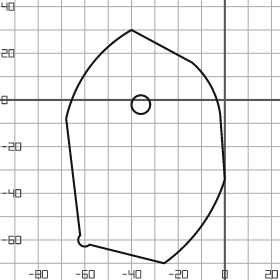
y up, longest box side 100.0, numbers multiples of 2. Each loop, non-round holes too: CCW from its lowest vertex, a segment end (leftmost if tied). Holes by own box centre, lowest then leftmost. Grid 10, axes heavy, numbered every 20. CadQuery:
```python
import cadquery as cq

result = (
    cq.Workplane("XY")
    .moveTo(-26.0, -70.0)
    .threePointArc((-10.0, -54.0), (0.0, -34.0))
    .lineTo(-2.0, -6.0)
    .threePointArc((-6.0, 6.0), (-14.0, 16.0))
    .lineTo(-40.0, 30.0)
    .threePointArc((-58.0, 14.0), (-68.0, -8.0))
    .lineTo(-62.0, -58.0)
    .threePointArc((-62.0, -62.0), (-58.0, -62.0))
    .close()
    .moveTo(-36.0, -2.0)
    .circle(4.0)
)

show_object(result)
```